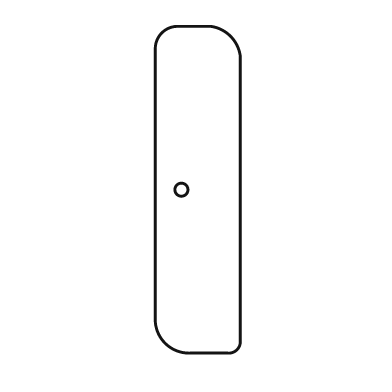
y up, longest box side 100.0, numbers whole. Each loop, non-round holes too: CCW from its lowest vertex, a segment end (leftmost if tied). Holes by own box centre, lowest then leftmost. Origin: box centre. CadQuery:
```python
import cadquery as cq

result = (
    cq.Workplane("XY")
    .moveTo(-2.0, -50.0)
    .lineTo(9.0, -50.0)
    .threePointArc((12.0, -49.0), (13.0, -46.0))
    .lineTo(13.0, 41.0)
    .threePointArc((10.0, 47.0), (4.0, 50.0))
    .lineTo(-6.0, 50.0)
    .threePointArc((-11.0, 48.0), (-13.0, 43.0))
    .lineTo(-13.0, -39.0)
    .threePointArc((-10.0, -47.0), (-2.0, -50.0))
    .close()
    .moveTo(-5.0, 0.0)
    .circle(2.0)
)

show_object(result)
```